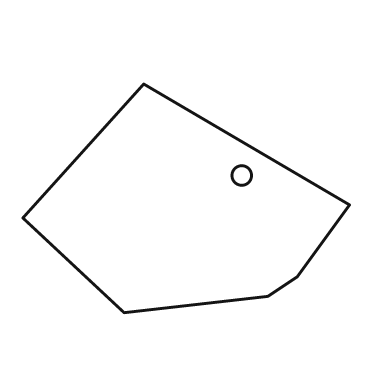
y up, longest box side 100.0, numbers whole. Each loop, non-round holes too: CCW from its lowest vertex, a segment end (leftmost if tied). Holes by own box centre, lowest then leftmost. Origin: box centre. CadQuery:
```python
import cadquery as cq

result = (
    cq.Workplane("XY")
    .moveTo(-19.0, -35.0)
    .lineTo(25.0, -30.0)
    .lineTo(34.0, -24.0)
    .lineTo(50.0, -2.0)
    .lineTo(-13.0, 35.0)
    .lineTo(-50.0, -6.0)
    .close()
    .moveTo(17.0, 7.0)
    .circle(3.0)
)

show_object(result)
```